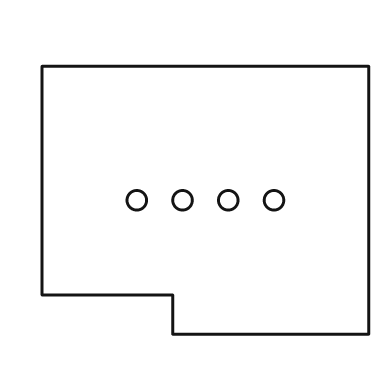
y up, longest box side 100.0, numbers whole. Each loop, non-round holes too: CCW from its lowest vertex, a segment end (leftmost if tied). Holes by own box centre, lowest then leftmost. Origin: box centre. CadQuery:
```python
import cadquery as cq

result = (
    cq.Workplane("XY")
    .moveTo(-10.0, -41.0)
    .lineTo(50.0, -41.0)
    .lineTo(50.0, 41.0)
    .lineTo(-50.0, 41.0)
    .lineTo(-50.0, -29.0)
    .lineTo(-10.0, -29.0)
    .close()
    .moveTo(-21.0, 0.0)
    .circle(3.0)
    .moveTo(-7.0, 0.0)
    .circle(3.0)
    .moveTo(7.0, 0.0)
    .circle(3.0)
    .moveTo(21.0, 0.0)
    .circle(3.0)
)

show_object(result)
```